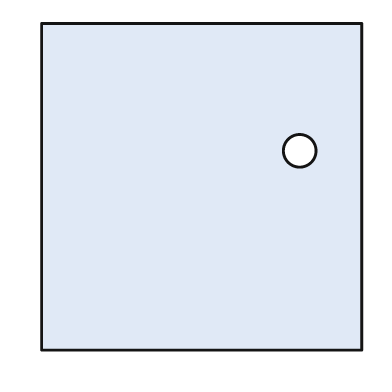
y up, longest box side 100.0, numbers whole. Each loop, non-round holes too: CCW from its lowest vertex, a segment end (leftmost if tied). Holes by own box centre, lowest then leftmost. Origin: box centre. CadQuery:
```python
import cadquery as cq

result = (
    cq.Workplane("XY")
    .moveTo(-49.0, -50.0)
    .lineTo(49.0, -50.0)
    .lineTo(49.0, 50.0)
    .lineTo(-49.0, 50.0)
    .close()
    .moveTo(30.0, 11.0)
    .circle(5.0)
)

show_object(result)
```